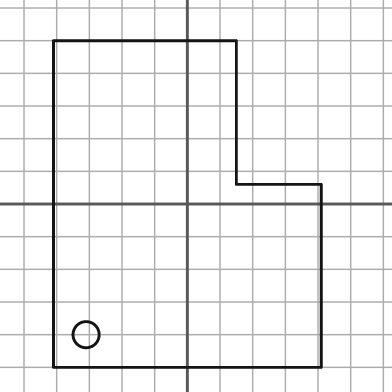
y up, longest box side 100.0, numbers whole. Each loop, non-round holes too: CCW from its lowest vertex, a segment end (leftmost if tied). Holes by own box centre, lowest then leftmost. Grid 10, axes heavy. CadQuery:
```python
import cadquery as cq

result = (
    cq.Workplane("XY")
    .moveTo(-41.0, -50.0)
    .lineTo(41.0, -50.0)
    .lineTo(41.0, 6.0)
    .lineTo(15.0, 6.0)
    .lineTo(15.0, 50.0)
    .lineTo(-41.0, 50.0)
    .close()
    .moveTo(-31.0, -40.0)
    .circle(4.0)
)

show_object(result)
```